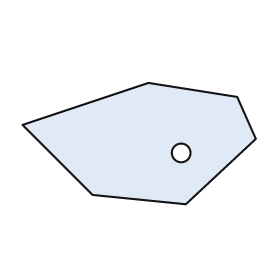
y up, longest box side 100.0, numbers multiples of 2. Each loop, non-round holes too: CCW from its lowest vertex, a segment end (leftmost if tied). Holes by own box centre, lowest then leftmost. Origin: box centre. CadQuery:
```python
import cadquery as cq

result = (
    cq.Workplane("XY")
    .moveTo(20.0, -26.0)
    .lineTo(50.0, 2.0)
    .lineTo(42.0, 20.0)
    .lineTo(4.0, 26.0)
    .lineTo(-50.0, 8.0)
    .lineTo(-20.0, -22.0)
    .close()
    .moveTo(18.0, -4.0)
    .circle(4.0)
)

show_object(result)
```